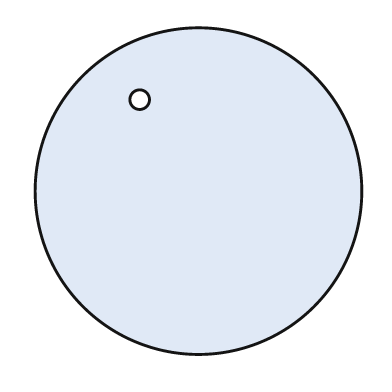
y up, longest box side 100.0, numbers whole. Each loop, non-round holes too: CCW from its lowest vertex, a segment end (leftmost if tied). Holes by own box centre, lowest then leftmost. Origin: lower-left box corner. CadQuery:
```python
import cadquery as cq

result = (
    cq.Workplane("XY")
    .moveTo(50.0, 50.0)
    .circle(50.0)
    .moveTo(32.0, 78.0)
    .circle(3.0)
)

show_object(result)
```